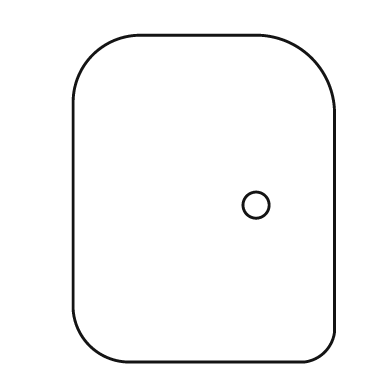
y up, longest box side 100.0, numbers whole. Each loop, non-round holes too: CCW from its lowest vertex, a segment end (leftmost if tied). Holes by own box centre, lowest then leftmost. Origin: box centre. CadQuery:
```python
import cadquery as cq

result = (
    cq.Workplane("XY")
    .moveTo(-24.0, -50.0)
    .lineTo(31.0, -50.0)
    .threePointArc((37.0, -47.0), (40.0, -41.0))
    .lineTo(40.0, 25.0)
    .threePointArc((33.0, 43.0), (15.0, 50.0))
    .lineTo(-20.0, 50.0)
    .threePointArc((-34.0, 44.0), (-40.0, 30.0))
    .lineTo(-40.0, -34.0)
    .threePointArc((-35.0, -45.0), (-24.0, -50.0))
    .close()
    .moveTo(16.0, -2.0)
    .circle(4.0)
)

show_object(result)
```